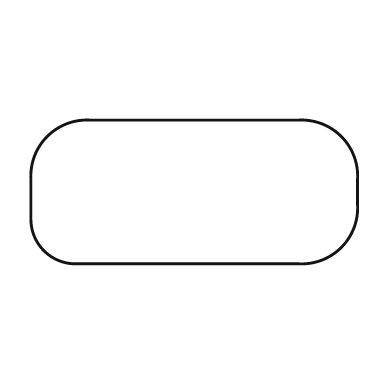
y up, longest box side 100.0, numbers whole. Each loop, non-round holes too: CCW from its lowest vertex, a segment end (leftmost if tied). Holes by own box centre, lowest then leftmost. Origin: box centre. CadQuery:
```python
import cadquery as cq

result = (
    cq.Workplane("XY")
    .moveTo(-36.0, -22.0)
    .lineTo(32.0, -22.0)
    .threePointArc((45.0, -17.0), (50.0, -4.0))
    .lineTo(50.0, 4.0)
    .threePointArc((45.0, 17.0), (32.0, 22.0))
    .lineTo(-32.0, 22.0)
    .threePointArc((-45.0, 17.0), (-50.0, 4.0))
    .lineTo(-50.0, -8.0)
    .threePointArc((-46.0, -18.0), (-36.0, -22.0))
    .close()
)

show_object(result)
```